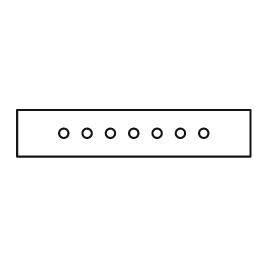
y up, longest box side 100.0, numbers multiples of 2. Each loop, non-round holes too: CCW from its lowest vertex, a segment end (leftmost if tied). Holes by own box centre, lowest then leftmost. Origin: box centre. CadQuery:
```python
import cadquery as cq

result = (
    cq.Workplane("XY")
    .moveTo(-50.0, -10.0)
    .lineTo(50.0, -10.0)
    .lineTo(50.0, 10.0)
    .lineTo(-50.0, 10.0)
    .close()
    .moveTo(-30.0, 0.0)
    .circle(2.0)
    .moveTo(-20.0, 0.0)
    .circle(2.0)
    .moveTo(-10.0, 0.0)
    .circle(2.0)
    .moveTo(0.0, 0.0)
    .circle(2.0)
    .moveTo(10.0, 0.0)
    .circle(2.0)
    .moveTo(20.0, 0.0)
    .circle(2.0)
    .moveTo(30.0, 0.0)
    .circle(2.0)
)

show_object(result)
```